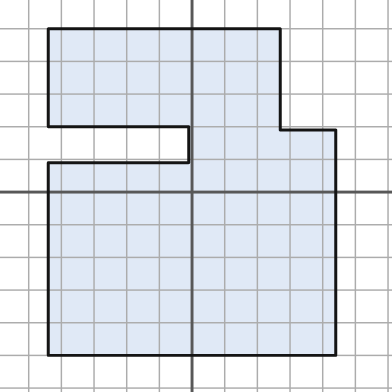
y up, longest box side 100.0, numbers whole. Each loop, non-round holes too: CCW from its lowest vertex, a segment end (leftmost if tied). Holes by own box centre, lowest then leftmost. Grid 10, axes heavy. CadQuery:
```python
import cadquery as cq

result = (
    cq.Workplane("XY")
    .moveTo(-44.0, -50.0)
    .lineTo(44.0, -50.0)
    .lineTo(44.0, 19.0)
    .lineTo(27.0, 19.0)
    .lineTo(27.0, 50.0)
    .lineTo(-44.0, 50.0)
    .lineTo(-44.0, 20.0)
    .lineTo(-1.0, 20.0)
    .lineTo(-1.0, 9.0)
    .lineTo(-44.0, 9.0)
    .close()
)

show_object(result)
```